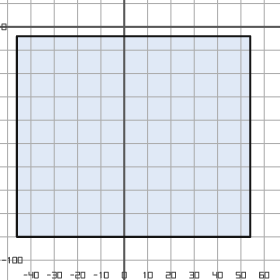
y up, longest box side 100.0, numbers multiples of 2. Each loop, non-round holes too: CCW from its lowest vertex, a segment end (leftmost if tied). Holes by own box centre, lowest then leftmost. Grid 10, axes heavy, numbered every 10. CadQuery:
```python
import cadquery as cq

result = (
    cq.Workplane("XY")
    .moveTo(-46.0, -90.0)
    .lineTo(54.0, -90.0)
    .lineTo(54.0, -4.0)
    .lineTo(-46.0, -4.0)
    .close()
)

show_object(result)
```